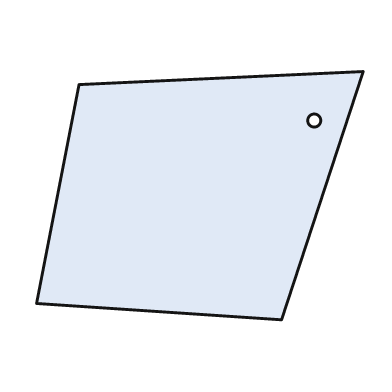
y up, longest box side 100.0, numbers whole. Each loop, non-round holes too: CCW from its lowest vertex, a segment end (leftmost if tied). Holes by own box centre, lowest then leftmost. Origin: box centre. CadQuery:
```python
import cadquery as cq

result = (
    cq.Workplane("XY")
    .moveTo(25.0, -38.0)
    .lineTo(50.0, 38.0)
    .lineTo(-37.0, 34.0)
    .lineTo(-50.0, -33.0)
    .close()
    .moveTo(35.0, 23.0)
    .circle(2.0)
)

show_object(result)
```